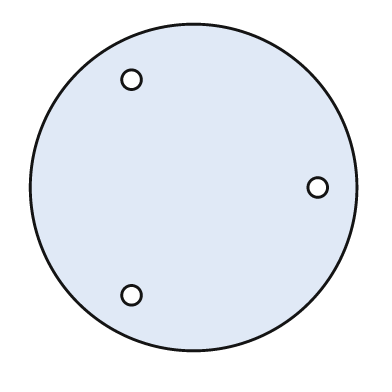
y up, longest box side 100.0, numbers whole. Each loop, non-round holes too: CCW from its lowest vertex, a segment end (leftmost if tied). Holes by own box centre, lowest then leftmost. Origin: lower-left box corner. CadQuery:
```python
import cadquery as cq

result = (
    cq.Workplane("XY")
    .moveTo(50.0, 50.0)
    .circle(50.0)
    .moveTo(31.0, 17.0)
    .circle(3.0)
    .moveTo(88.0, 50.0)
    .circle(3.0)
    .moveTo(31.0, 83.0)
    .circle(3.0)
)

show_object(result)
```